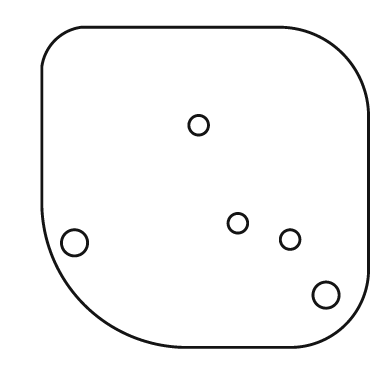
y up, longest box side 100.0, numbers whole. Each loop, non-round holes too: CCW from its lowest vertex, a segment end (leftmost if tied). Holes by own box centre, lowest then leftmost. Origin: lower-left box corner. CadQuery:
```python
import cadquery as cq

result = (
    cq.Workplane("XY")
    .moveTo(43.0, 0.0)
    .lineTo(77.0, 0.0)
    .threePointArc((93.0, 7.0), (100.0, 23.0))
    .lineTo(100.0, 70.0)
    .threePointArc((92.0, 90.0), (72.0, 98.0))
    .lineTo(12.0, 98.0)
    .threePointArc((4.0, 94.0), (0.0, 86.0))
    .lineTo(0.0, 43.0)
    .threePointArc((13.0, 13.0), (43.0, 0.0))
    .close()
    .moveTo(87.0, 16.0)
    .circle(4.0)
    .moveTo(10.0, 32.0)
    .circle(4.0)
    .moveTo(76.0, 33.0)
    .circle(3.0)
    .moveTo(60.0, 38.0)
    .circle(3.0)
    .moveTo(48.0, 68.0)
    .circle(3.0)
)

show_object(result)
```